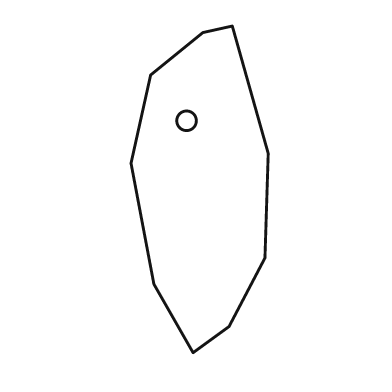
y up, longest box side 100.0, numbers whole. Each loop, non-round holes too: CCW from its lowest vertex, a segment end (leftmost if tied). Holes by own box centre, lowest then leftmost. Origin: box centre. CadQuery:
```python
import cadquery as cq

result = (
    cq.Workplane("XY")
    .moveTo(-2.0, -50.0)
    .lineTo(9.0, -42.0)
    .lineTo(20.0, -21.0)
    .lineTo(21.0, 11.0)
    .lineTo(10.0, 50.0)
    .lineTo(1.0, 48.0)
    .lineTo(-15.0, 35.0)
    .lineTo(-21.0, 8.0)
    .lineTo(-14.0, -29.0)
    .close()
    .moveTo(-4.0, 21.0)
    .circle(3.0)
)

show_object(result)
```